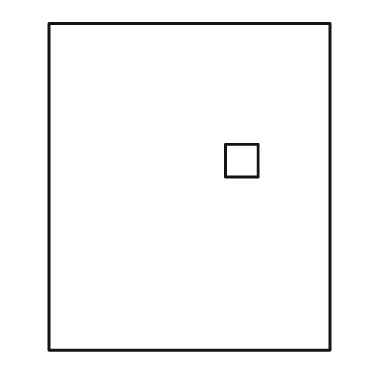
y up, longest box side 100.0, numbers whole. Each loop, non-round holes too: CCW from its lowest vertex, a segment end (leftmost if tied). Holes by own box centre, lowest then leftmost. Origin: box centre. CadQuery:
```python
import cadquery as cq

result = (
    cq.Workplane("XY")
    .moveTo(-43.0, -50.0)
    .lineTo(43.0, -50.0)
    .lineTo(43.0, 50.0)
    .lineTo(-43.0, 50.0)
    .close()
    .moveTo(11.0, 3.0)
    .lineTo(21.0, 3.0)
    .lineTo(21.0, 13.0)
    .lineTo(11.0, 13.0)
    .close()
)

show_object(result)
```